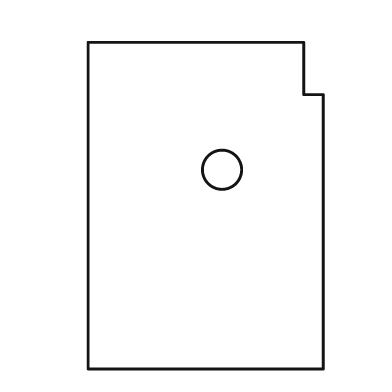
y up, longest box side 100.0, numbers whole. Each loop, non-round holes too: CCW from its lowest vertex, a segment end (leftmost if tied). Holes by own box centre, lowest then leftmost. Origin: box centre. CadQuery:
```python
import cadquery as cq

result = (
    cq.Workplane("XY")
    .moveTo(-36.0, -50.0)
    .lineTo(36.0, -50.0)
    .lineTo(36.0, 34.0)
    .lineTo(30.0, 34.0)
    .lineTo(30.0, 50.0)
    .lineTo(-36.0, 50.0)
    .close()
    .moveTo(5.0, 11.0)
    .circle(6.0)
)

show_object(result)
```